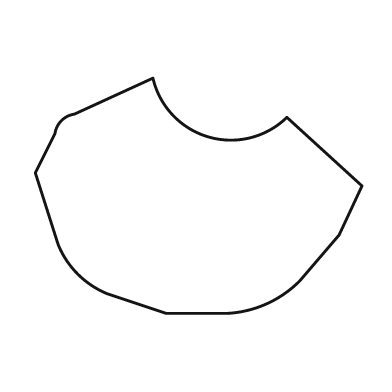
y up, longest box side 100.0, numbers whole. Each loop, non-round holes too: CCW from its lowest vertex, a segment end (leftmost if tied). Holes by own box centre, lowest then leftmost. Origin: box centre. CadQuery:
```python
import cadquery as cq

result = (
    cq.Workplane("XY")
    .moveTo(-10.0, -36.0)
    .lineTo(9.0, -36.0)
    .threePointArc((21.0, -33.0), (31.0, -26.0))
    .lineTo(43.0, -12.0)
    .lineTo(50.0, 3.0)
    .lineTo(27.0, 24.0)
    .threePointArc((3.0, 18.0), (-14.0, 36.0))
    .lineTo(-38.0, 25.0)
    .threePointArc((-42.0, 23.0), (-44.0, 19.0))
    .lineTo(-50.0, 7.0)
    .lineTo(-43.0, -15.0)
    .threePointArc((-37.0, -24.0), (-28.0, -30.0))
    .close()
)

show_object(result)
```